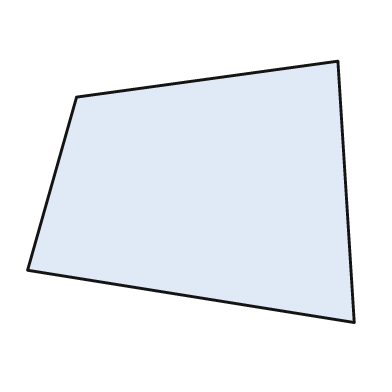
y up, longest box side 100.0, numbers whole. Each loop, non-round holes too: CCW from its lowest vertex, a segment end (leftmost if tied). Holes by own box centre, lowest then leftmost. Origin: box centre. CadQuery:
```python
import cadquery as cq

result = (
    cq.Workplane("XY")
    .moveTo(50.0, -40.0)
    .lineTo(45.0, 40.0)
    .lineTo(-35.0, 29.0)
    .lineTo(-50.0, -24.0)
    .close()
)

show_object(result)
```